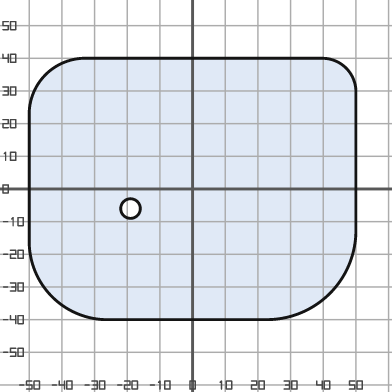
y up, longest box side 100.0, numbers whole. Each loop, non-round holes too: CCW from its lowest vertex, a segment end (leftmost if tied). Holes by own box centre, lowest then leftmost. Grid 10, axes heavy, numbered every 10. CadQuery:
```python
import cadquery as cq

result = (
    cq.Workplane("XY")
    .moveTo(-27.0, -40.0)
    .lineTo(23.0, -40.0)
    .threePointArc((42.0, -32.0), (50.0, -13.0))
    .lineTo(50.0, 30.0)
    .threePointArc((47.0, 37.0), (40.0, 40.0))
    .lineTo(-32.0, 40.0)
    .threePointArc((-45.0, 35.0), (-50.0, 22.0))
    .lineTo(-50.0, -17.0)
    .threePointArc((-43.0, -33.0), (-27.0, -40.0))
    .close()
    .moveTo(-19.0, -6.0)
    .circle(3.0)
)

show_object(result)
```